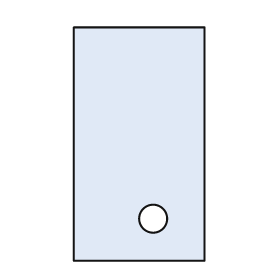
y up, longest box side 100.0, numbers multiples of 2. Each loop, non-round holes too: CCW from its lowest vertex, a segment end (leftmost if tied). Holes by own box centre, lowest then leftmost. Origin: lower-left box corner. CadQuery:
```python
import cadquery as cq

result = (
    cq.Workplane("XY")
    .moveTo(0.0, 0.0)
    .lineTo(56.0, 0.0)
    .lineTo(56.0, 100.0)
    .lineTo(0.0, 100.0)
    .close()
    .moveTo(34.0, 18.0)
    .circle(6.0)
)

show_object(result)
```